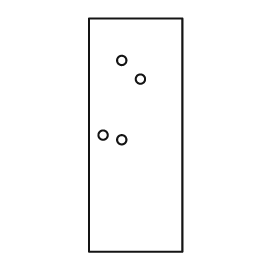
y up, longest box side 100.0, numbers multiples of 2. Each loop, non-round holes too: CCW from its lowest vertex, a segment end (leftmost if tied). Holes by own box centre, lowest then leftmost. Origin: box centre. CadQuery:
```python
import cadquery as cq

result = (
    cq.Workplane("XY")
    .moveTo(-20.0, -50.0)
    .lineTo(20.0, -50.0)
    .lineTo(20.0, 50.0)
    .lineTo(-20.0, 50.0)
    .close()
    .moveTo(-6.0, -2.0)
    .circle(2.0)
    .moveTo(-14.0, 0.0)
    .circle(2.0)
    .moveTo(2.0, 24.0)
    .circle(2.0)
    .moveTo(-6.0, 32.0)
    .circle(2.0)
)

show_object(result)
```